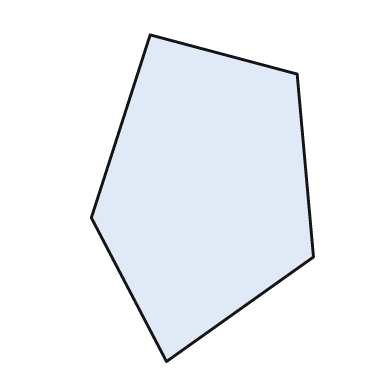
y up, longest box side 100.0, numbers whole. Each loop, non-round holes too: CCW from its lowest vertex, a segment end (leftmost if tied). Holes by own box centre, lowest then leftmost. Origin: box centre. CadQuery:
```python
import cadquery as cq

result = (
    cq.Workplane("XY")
    .moveTo(-11.0, -50.0)
    .lineTo(34.0, -18.0)
    .lineTo(29.0, 38.0)
    .lineTo(-16.0, 50.0)
    .lineTo(-34.0, -6.0)
    .close()
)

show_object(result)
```